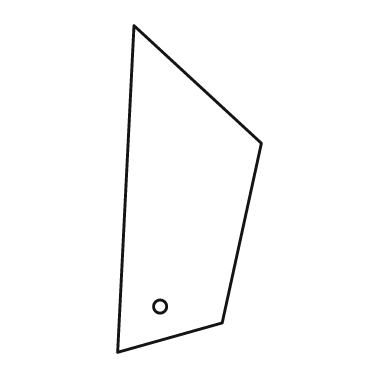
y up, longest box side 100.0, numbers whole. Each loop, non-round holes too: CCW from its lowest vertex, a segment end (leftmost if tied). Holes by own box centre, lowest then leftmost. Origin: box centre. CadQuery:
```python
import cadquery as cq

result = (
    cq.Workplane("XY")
    .moveTo(-22.0, -50.0)
    .lineTo(10.0, -41.0)
    .lineTo(22.0, 14.0)
    .lineTo(-17.0, 50.0)
    .close()
    .moveTo(-9.0, -36.0)
    .circle(2.0)
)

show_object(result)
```